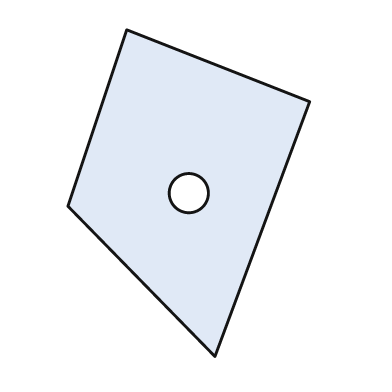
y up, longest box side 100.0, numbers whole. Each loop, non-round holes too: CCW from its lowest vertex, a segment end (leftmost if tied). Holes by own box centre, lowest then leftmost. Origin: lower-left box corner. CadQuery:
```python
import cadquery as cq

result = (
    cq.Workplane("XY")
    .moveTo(45.0, 0.0)
    .lineTo(74.0, 78.0)
    .lineTo(18.0, 100.0)
    .lineTo(0.0, 46.0)
    .close()
    .moveTo(37.0, 50.0)
    .circle(6.0)
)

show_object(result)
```